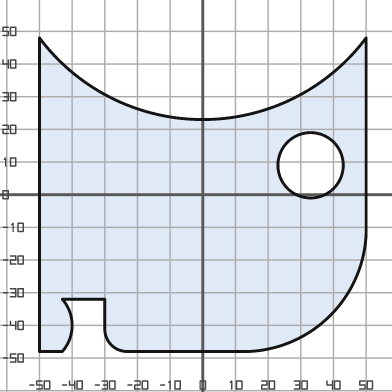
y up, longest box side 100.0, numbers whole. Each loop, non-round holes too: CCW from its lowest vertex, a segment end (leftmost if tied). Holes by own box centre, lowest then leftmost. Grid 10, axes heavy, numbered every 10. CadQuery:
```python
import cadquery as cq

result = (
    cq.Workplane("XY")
    .moveTo(-50.0, -48.0)
    .lineTo(-43.0, -48.0)
    .threePointArc((-40.0, -40.0), (-43.0, -32.0))
    .lineTo(-30.0, -32.0)
    .lineTo(-30.0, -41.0)
    .threePointArc((-28.0, -46.0), (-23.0, -48.0))
    .lineTo(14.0, -48.0)
    .threePointArc((39.0, -37.0), (50.0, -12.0))
    .lineTo(50.0, 48.0)
    .threePointArc((0.0, 23.0), (-50.0, 48.0))
    .close()
    .moveTo(33.0, 9.0)
    .circle(10.0)
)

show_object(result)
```